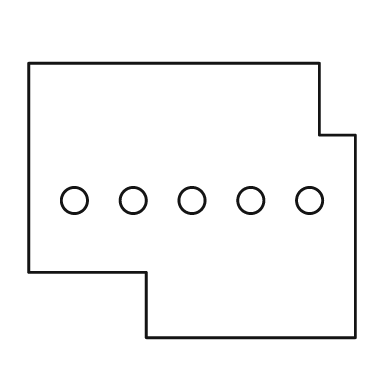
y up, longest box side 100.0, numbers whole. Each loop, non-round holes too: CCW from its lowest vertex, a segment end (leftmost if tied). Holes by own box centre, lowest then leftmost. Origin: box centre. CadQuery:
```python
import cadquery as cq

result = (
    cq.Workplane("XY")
    .moveTo(-14.0, -42.0)
    .lineTo(50.0, -42.0)
    .lineTo(50.0, 20.0)
    .lineTo(39.0, 20.0)
    .lineTo(39.0, 42.0)
    .lineTo(-50.0, 42.0)
    .lineTo(-50.0, -22.0)
    .lineTo(-14.0, -22.0)
    .close()
    .moveTo(-36.0, 0.0)
    .circle(4.0)
    .moveTo(-18.0, 0.0)
    .circle(4.0)
    .moveTo(0.0, 0.0)
    .circle(4.0)
    .moveTo(18.0, 0.0)
    .circle(4.0)
    .moveTo(36.0, 0.0)
    .circle(4.0)
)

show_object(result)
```